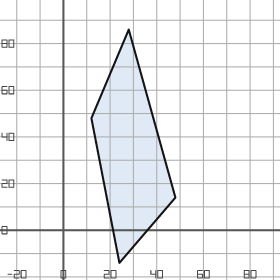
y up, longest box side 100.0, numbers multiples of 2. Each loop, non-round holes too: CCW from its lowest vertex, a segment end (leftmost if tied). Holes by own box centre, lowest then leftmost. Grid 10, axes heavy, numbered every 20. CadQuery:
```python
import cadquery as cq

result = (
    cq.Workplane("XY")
    .moveTo(24.0, -14.0)
    .lineTo(48.0, 14.0)
    .lineTo(28.0, 86.0)
    .lineTo(12.0, 48.0)
    .close()
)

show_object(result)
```